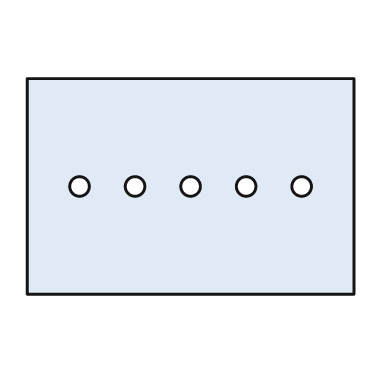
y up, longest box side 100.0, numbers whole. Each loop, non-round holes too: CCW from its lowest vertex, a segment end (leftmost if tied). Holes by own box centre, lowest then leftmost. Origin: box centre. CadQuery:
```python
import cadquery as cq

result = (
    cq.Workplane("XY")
    .moveTo(-50.0, -33.0)
    .lineTo(50.0, -33.0)
    .lineTo(50.0, 33.0)
    .lineTo(-50.0, 33.0)
    .close()
    .moveTo(-34.0, 0.0)
    .circle(3.0)
    .moveTo(-17.0, 0.0)
    .circle(3.0)
    .moveTo(0.0, 0.0)
    .circle(3.0)
    .moveTo(17.0, 0.0)
    .circle(3.0)
    .moveTo(34.0, 0.0)
    .circle(3.0)
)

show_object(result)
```